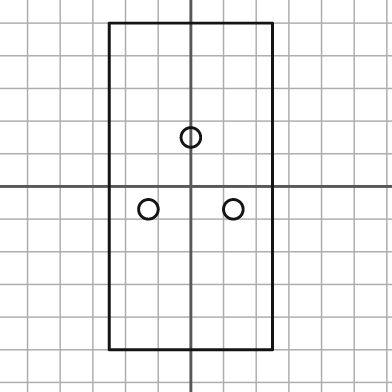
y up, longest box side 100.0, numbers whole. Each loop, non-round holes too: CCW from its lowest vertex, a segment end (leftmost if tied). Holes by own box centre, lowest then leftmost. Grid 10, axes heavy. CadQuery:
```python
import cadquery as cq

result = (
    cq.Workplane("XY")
    .moveTo(-25.0, -50.0)
    .lineTo(25.0, -50.0)
    .lineTo(25.0, 50.0)
    .lineTo(-25.0, 50.0)
    .close()
    .moveTo(-13.0, -7.0)
    .circle(3.0)
    .moveTo(13.0, -7.0)
    .circle(3.0)
    .moveTo(0.0, 15.0)
    .circle(3.0)
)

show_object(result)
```